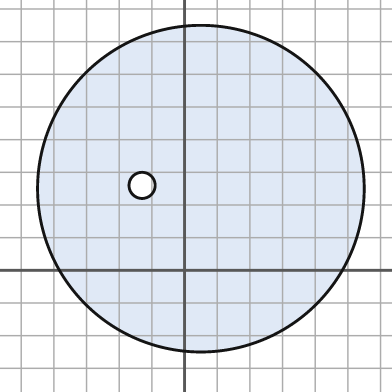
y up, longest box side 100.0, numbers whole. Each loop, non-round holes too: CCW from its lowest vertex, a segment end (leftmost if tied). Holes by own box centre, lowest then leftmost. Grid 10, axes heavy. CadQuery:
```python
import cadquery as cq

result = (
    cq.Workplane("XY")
    .moveTo(5.0, 25.0)
    .circle(50.0)
    .moveTo(-13.0, 26.0)
    .circle(4.0)
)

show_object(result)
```